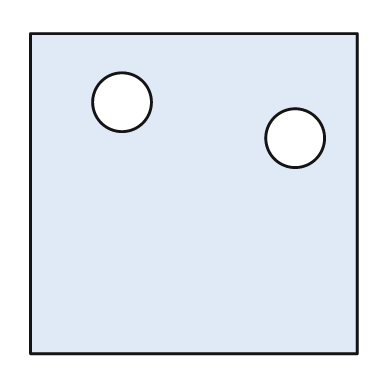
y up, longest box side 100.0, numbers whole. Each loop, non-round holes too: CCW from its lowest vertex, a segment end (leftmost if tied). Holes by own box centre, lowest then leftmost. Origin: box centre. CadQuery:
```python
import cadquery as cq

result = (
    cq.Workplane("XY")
    .moveTo(-50.0, -49.0)
    .lineTo(50.0, -49.0)
    .lineTo(50.0, 49.0)
    .lineTo(-50.0, 49.0)
    .close()
    .moveTo(31.0, 17.0)
    .circle(9.0)
    .moveTo(-22.0, 28.0)
    .circle(9.0)
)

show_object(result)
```